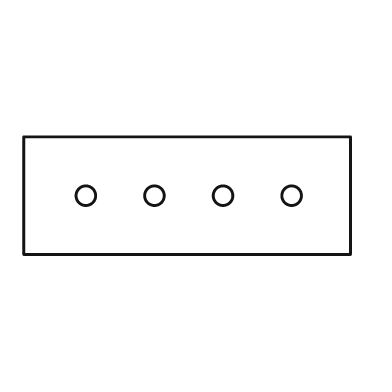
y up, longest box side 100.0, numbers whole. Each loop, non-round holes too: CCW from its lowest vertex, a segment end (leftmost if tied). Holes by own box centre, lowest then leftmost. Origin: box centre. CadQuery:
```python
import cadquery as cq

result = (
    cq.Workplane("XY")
    .moveTo(-50.0, -18.0)
    .lineTo(50.0, -18.0)
    .lineTo(50.0, 18.0)
    .lineTo(-50.0, 18.0)
    .close()
    .moveTo(-31.0, 0.0)
    .circle(3.0)
    .moveTo(-10.0, 0.0)
    .circle(3.0)
    .moveTo(11.0, 0.0)
    .circle(3.0)
    .moveTo(32.0, 0.0)
    .circle(3.0)
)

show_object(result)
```